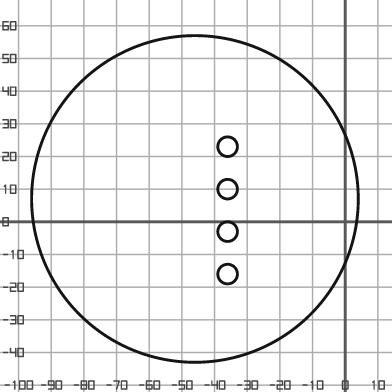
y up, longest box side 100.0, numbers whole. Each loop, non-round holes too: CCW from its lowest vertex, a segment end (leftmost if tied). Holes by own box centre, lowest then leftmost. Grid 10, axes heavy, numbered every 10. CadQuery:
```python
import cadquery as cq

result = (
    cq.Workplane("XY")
    .moveTo(-46.0, 7.0)
    .circle(50.0)
    .moveTo(-36.0, -16.0)
    .circle(3.0)
    .moveTo(-36.0, -3.0)
    .circle(3.0)
    .moveTo(-36.0, 10.0)
    .circle(3.0)
    .moveTo(-36.0, 23.0)
    .circle(3.0)
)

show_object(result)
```